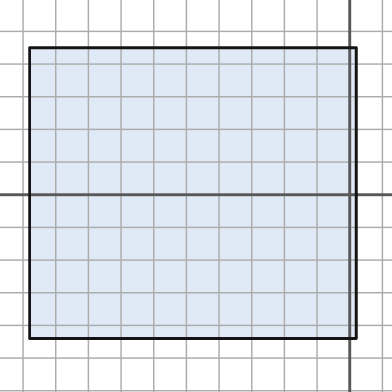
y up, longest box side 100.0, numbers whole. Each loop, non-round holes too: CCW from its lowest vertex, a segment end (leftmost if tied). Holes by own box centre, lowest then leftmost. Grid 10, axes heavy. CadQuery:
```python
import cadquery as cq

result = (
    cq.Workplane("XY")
    .moveTo(-98.0, -44.0)
    .lineTo(2.0, -44.0)
    .lineTo(2.0, 45.0)
    .lineTo(-98.0, 45.0)
    .close()
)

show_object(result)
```